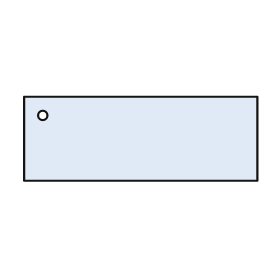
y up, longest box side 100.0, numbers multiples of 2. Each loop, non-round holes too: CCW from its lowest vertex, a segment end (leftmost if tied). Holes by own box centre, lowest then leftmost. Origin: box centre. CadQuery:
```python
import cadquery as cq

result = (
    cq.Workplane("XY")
    .moveTo(-50.0, -18.0)
    .lineTo(50.0, -18.0)
    .lineTo(50.0, 18.0)
    .lineTo(-50.0, 18.0)
    .close()
    .moveTo(-42.0, 10.0)
    .circle(2.0)
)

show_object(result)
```